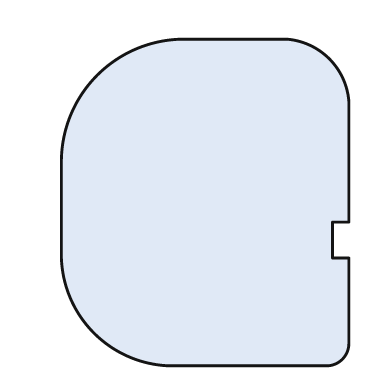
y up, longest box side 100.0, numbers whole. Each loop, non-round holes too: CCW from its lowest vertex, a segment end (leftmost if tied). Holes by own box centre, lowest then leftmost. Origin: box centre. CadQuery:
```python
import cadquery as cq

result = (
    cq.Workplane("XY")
    .moveTo(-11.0, -50.0)
    .lineTo(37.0, -50.0)
    .threePointArc((42.0, -48.0), (44.0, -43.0))
    .lineTo(44.0, -17.0)
    .lineTo(39.0, -17.0)
    .lineTo(39.0, -6.0)
    .lineTo(44.0, -6.0)
    .lineTo(44.0, 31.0)
    .threePointArc((38.0, 44.0), (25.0, 50.0))
    .lineTo(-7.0, 50.0)
    .threePointArc((-33.0, 39.0), (-44.0, 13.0))
    .lineTo(-44.0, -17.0)
    .threePointArc((-34.0, -40.0), (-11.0, -50.0))
    .close()
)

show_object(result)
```